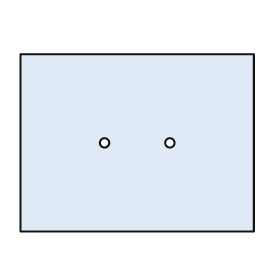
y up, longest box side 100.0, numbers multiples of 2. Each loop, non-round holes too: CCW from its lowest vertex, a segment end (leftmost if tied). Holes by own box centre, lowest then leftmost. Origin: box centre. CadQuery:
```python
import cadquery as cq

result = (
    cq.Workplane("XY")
    .moveTo(-50.0, -38.0)
    .lineTo(50.0, -38.0)
    .lineTo(50.0, 38.0)
    .lineTo(-50.0, 38.0)
    .close()
    .moveTo(-14.0, 0.0)
    .circle(2.0)
    .moveTo(14.0, 0.0)
    .circle(2.0)
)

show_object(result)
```